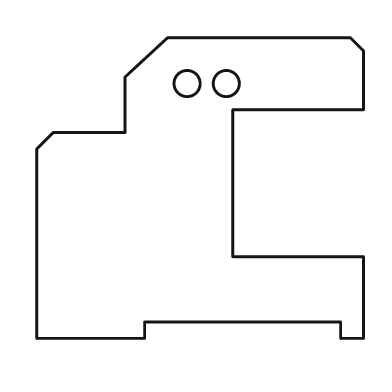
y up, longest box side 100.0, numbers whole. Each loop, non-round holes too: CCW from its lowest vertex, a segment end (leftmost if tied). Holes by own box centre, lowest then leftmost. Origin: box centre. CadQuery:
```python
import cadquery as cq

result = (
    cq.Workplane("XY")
    .moveTo(-50.0, -46.0)
    .lineTo(-17.0, -46.0)
    .lineTo(-17.0, -41.0)
    .lineTo(43.0, -41.0)
    .lineTo(43.0, -46.0)
    .lineTo(50.0, -46.0)
    .lineTo(50.0, -21.0)
    .lineTo(10.0, -21.0)
    .lineTo(10.0, 24.0)
    .lineTo(50.0, 24.0)
    .lineTo(50.0, 42.0)
    .lineTo(46.0, 46.0)
    .lineTo(-10.0, 46.0)
    .lineTo(-23.0, 34.0)
    .lineTo(-23.0, 17.0)
    .lineTo(-45.0, 17.0)
    .lineTo(-50.0, 12.0)
    .close()
    .moveTo(-4.0, 32.0)
    .circle(4.0)
    .moveTo(8.0, 32.0)
    .circle(4.0)
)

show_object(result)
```